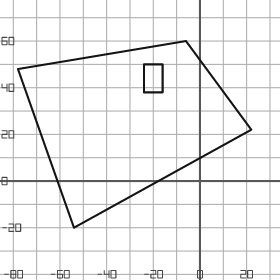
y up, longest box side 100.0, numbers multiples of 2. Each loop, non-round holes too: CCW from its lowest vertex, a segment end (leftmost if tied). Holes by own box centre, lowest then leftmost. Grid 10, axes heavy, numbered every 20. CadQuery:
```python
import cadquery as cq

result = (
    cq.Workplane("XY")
    .moveTo(-54.0, -20.0)
    .lineTo(22.0, 22.0)
    .lineTo(-6.0, 60.0)
    .lineTo(-78.0, 48.0)
    .close()
    .moveTo(-24.0, 38.0)
    .lineTo(-16.0, 38.0)
    .lineTo(-16.0, 50.0)
    .lineTo(-24.0, 50.0)
    .close()
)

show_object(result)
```